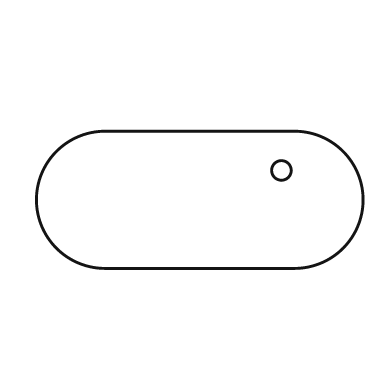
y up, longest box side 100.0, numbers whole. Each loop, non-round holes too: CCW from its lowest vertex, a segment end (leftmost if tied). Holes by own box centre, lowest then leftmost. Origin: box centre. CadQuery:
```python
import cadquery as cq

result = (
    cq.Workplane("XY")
    .moveTo(-29.0, -21.0)
    .lineTo(29.0, -21.0)
    .threePointArc((50.0, 0.0), (29.0, 21.0))
    .lineTo(-29.0, 21.0)
    .threePointArc((-50.0, 0.0), (-29.0, -21.0))
    .close()
    .moveTo(25.0, 9.0)
    .circle(3.0)
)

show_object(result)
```